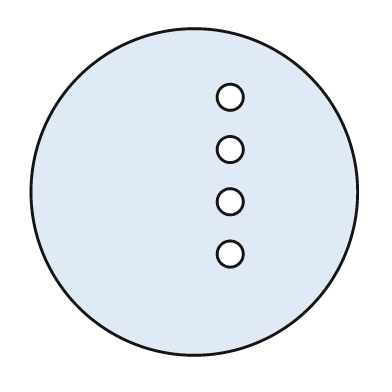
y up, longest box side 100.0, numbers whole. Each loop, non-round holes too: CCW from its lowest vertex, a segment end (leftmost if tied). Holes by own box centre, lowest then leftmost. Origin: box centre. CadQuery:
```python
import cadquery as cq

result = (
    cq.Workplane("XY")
    .moveTo(0.0, 0.0)
    .circle(50.0)
    .moveTo(11.0, -19.0)
    .circle(4.0)
    .moveTo(11.0, -3.0)
    .circle(4.0)
    .moveTo(11.0, 13.0)
    .circle(4.0)
    .moveTo(11.0, 29.0)
    .circle(4.0)
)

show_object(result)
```